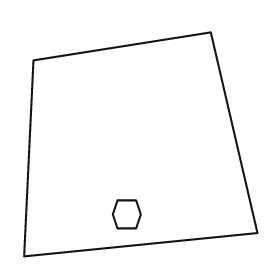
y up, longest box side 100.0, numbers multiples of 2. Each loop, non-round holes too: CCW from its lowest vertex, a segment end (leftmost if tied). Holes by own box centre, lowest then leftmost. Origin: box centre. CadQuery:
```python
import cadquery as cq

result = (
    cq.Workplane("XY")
    .moveTo(-50.0, -48.0)
    .lineTo(50.0, -38.0)
    .lineTo(30.0, 48.0)
    .lineTo(-46.0, 36.0)
    .close()
    .moveTo(-10.0, -36.0)
    .lineTo(-2.0, -36.0)
    .lineTo(0.0, -30.0)
    .lineTo(-2.0, -24.0)
    .lineTo(-10.0, -24.0)
    .lineTo(-12.0, -30.0)
    .close()
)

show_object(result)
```